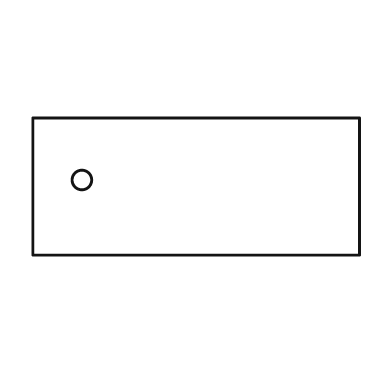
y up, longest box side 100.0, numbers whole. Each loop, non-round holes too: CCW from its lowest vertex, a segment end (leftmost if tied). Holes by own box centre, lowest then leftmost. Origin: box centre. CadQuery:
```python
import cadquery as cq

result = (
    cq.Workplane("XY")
    .moveTo(-50.0, -21.0)
    .lineTo(50.0, -21.0)
    .lineTo(50.0, 21.0)
    .lineTo(-50.0, 21.0)
    .close()
    .moveTo(-35.0, 2.0)
    .circle(3.0)
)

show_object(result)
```